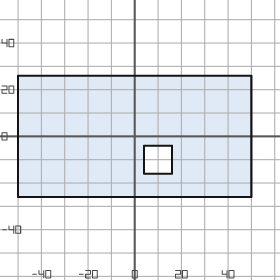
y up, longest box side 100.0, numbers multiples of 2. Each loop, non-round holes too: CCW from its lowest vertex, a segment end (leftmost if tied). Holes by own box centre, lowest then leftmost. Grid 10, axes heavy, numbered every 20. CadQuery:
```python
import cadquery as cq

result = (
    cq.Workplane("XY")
    .moveTo(-50.0, -26.0)
    .lineTo(50.0, -26.0)
    .lineTo(50.0, 26.0)
    .lineTo(-50.0, 26.0)
    .close()
    .moveTo(4.0, -16.0)
    .lineTo(16.0, -16.0)
    .lineTo(16.0, -4.0)
    .lineTo(4.0, -4.0)
    .close()
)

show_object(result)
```